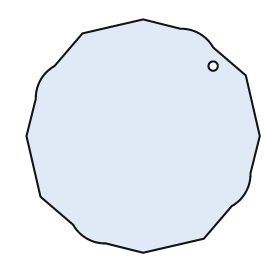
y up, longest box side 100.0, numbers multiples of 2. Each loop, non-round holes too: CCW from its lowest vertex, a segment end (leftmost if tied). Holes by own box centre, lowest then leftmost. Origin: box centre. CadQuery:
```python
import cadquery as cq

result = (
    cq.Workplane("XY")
    .moveTo(0.0, -50.0)
    .lineTo(26.0, -44.0)
    .lineTo(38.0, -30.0)
    .threePointArc((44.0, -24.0), (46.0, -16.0))
    .lineTo(50.0, 0.0)
    .lineTo(44.0, 26.0)
    .lineTo(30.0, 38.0)
    .threePointArc((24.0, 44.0), (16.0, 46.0))
    .lineTo(0.0, 50.0)
    .lineTo(-26.0, 44.0)
    .lineTo(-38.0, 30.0)
    .threePointArc((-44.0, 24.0), (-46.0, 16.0))
    .lineTo(-50.0, 0.0)
    .lineTo(-44.0, -26.0)
    .lineTo(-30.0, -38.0)
    .threePointArc((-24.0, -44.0), (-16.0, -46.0))
    .close()
    .moveTo(30.0, 30.0)
    .circle(2.0)
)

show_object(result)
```